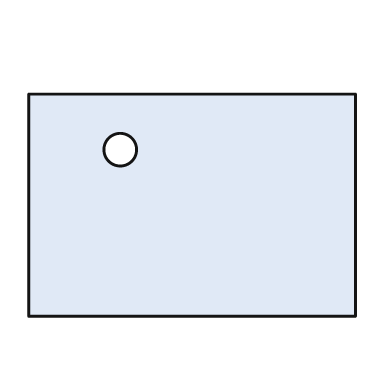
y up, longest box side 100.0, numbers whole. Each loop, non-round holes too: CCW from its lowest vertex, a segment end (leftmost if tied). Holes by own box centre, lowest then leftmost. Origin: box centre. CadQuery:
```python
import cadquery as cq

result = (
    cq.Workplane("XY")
    .moveTo(-50.0, -34.0)
    .lineTo(50.0, -34.0)
    .lineTo(50.0, 34.0)
    .lineTo(-50.0, 34.0)
    .close()
    .moveTo(-22.0, 17.0)
    .circle(5.0)
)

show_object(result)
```